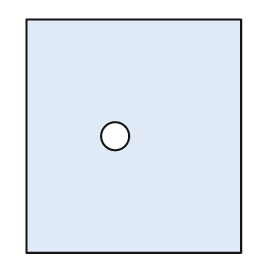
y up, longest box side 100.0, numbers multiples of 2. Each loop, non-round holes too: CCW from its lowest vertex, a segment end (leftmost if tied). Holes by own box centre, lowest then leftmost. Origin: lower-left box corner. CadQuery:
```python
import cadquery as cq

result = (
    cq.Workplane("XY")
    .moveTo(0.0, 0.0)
    .lineTo(92.0, 0.0)
    .lineTo(92.0, 100.0)
    .lineTo(0.0, 100.0)
    .close()
    .moveTo(38.0, 50.0)
    .circle(6.0)
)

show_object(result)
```